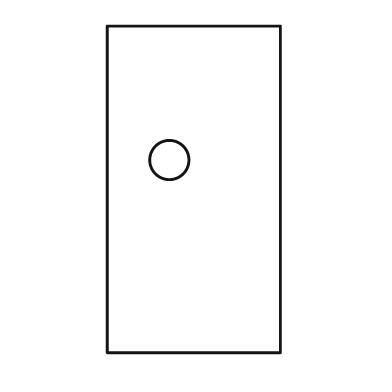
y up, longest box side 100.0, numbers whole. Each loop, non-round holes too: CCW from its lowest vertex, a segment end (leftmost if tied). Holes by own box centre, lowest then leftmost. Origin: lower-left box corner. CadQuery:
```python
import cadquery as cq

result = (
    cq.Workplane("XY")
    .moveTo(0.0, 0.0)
    .lineTo(53.0, 0.0)
    .lineTo(53.0, 100.0)
    .lineTo(0.0, 100.0)
    .close()
    .moveTo(19.0, 59.0)
    .circle(6.0)
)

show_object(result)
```